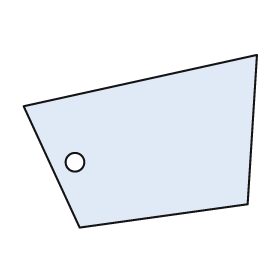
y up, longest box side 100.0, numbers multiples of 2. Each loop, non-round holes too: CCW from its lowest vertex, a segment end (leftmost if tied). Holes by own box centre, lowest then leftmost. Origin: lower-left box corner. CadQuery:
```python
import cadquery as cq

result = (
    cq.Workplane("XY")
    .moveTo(24.0, 0.0)
    .lineTo(96.0, 10.0)
    .lineTo(100.0, 74.0)
    .lineTo(0.0, 52.0)
    .close()
    .moveTo(22.0, 28.0)
    .circle(4.0)
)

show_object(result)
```